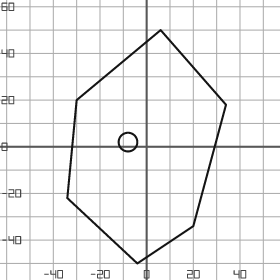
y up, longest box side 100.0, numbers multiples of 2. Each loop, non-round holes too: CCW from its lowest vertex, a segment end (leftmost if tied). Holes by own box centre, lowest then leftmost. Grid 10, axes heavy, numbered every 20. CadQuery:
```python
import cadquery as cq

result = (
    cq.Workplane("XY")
    .moveTo(-4.0, -50.0)
    .lineTo(20.0, -34.0)
    .lineTo(34.0, 18.0)
    .lineTo(6.0, 50.0)
    .lineTo(-30.0, 20.0)
    .lineTo(-34.0, -22.0)
    .close()
    .moveTo(-8.0, 2.0)
    .circle(4.0)
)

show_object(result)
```